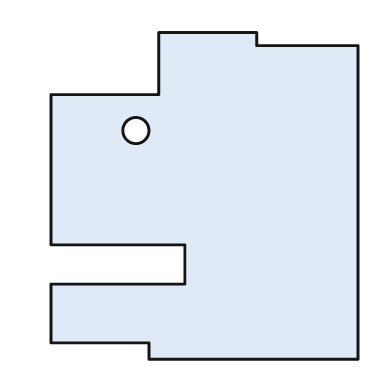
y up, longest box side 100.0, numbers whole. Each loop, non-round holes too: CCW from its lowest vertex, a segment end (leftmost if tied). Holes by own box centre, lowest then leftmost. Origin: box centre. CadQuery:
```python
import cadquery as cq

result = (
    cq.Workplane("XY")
    .moveTo(-17.0, -50.0)
    .lineTo(47.0, -50.0)
    .lineTo(47.0, 46.0)
    .lineTo(16.0, 46.0)
    .lineTo(16.0, 50.0)
    .lineTo(-14.0, 50.0)
    .lineTo(-14.0, 31.0)
    .lineTo(-47.0, 31.0)
    .lineTo(-47.0, -15.0)
    .lineTo(-6.0, -15.0)
    .lineTo(-6.0, -27.0)
    .lineTo(-47.0, -27.0)
    .lineTo(-47.0, -45.0)
    .lineTo(-17.0, -45.0)
    .close()
    .moveTo(-21.0, 20.0)
    .circle(4.0)
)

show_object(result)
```